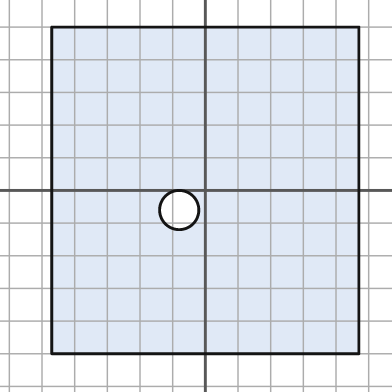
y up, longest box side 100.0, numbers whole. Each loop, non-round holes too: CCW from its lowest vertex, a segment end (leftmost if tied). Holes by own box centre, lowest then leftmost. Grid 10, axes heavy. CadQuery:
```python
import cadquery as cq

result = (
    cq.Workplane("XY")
    .moveTo(-47.0, -50.0)
    .lineTo(47.0, -50.0)
    .lineTo(47.0, 50.0)
    .lineTo(-47.0, 50.0)
    .close()
    .moveTo(-8.0, -6.0)
    .circle(6.0)
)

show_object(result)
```